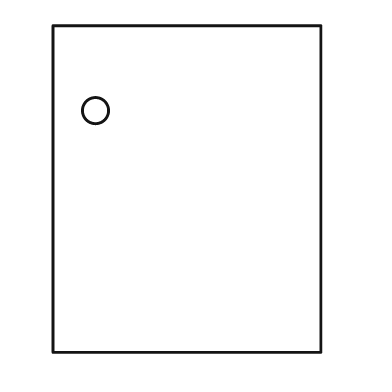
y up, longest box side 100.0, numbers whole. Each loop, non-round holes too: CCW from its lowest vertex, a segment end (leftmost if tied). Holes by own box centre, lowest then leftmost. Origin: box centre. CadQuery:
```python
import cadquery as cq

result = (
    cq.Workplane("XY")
    .moveTo(-41.0, -50.0)
    .lineTo(41.0, -50.0)
    .lineTo(41.0, 50.0)
    .lineTo(-41.0, 50.0)
    .close()
    .moveTo(-28.0, 24.0)
    .circle(4.0)
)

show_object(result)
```